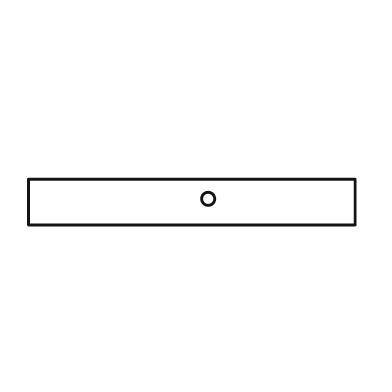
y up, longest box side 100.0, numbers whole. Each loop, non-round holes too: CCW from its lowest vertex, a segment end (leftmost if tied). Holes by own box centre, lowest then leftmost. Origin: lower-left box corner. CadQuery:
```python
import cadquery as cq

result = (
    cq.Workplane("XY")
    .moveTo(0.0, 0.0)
    .lineTo(100.0, 0.0)
    .lineTo(100.0, 14.0)
    .lineTo(0.0, 14.0)
    .close()
    .moveTo(55.0, 8.0)
    .circle(2.0)
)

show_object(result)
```